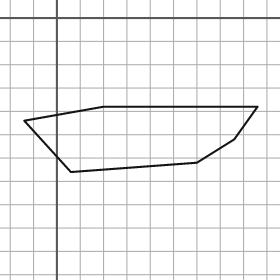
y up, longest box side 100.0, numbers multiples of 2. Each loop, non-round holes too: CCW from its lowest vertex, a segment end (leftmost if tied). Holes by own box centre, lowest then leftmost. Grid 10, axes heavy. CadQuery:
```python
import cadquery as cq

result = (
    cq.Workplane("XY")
    .moveTo(6.0, -66.0)
    .lineTo(60.0, -62.0)
    .lineTo(76.0, -52.0)
    .lineTo(86.0, -38.0)
    .lineTo(20.0, -38.0)
    .lineTo(-14.0, -44.0)
    .close()
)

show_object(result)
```